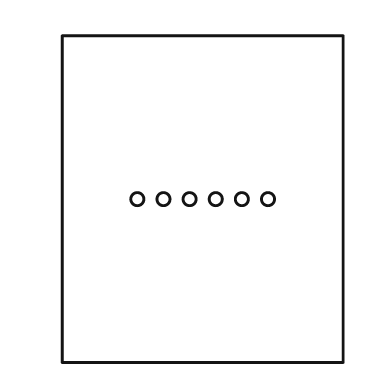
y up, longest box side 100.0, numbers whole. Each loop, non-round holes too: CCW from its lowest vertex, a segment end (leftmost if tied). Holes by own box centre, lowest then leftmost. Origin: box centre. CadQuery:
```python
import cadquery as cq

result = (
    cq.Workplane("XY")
    .moveTo(-43.0, -50.0)
    .lineTo(43.0, -50.0)
    .lineTo(43.0, 50.0)
    .lineTo(-43.0, 50.0)
    .close()
    .moveTo(-20.0, 0.0)
    .circle(2.0)
    .moveTo(-12.0, 0.0)
    .circle(2.0)
    .moveTo(-4.0, 0.0)
    .circle(2.0)
    .moveTo(4.0, 0.0)
    .circle(2.0)
    .moveTo(12.0, 0.0)
    .circle(2.0)
    .moveTo(20.0, 0.0)
    .circle(2.0)
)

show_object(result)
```